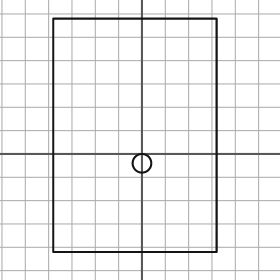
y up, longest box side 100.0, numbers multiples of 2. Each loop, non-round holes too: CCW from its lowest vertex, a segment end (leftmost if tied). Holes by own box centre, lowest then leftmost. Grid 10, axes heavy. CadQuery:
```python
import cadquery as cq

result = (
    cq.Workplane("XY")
    .moveTo(-38.0, -42.0)
    .lineTo(32.0, -42.0)
    .lineTo(32.0, 58.0)
    .lineTo(-38.0, 58.0)
    .close()
    .moveTo(0.0, -4.0)
    .circle(4.0)
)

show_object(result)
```